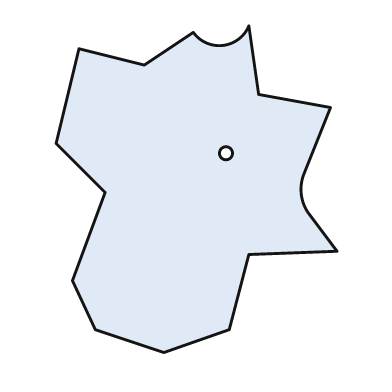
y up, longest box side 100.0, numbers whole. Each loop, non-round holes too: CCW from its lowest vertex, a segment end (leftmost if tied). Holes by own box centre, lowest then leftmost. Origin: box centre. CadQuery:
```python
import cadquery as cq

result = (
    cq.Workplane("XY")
    .moveTo(-10.0, -50.0)
    .lineTo(10.0, -43.0)
    .lineTo(16.0, -20.0)
    .lineTo(43.0, -19.0)
    .lineTo(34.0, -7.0)
    .threePointArc((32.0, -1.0), (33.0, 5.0))
    .lineTo(41.0, 25.0)
    .lineTo(19.0, 29.0)
    .lineTo(16.0, 50.0)
    .threePointArc((8.0, 44.0), (-1.0, 48.0))
    .lineTo(-16.0, 38.0)
    .lineTo(-36.0, 43.0)
    .lineTo(-43.0, 14.0)
    .lineTo(-28.0, -1.0)
    .lineTo(-38.0, -28.0)
    .lineTo(-31.0, -43.0)
    .close()
    .moveTo(9.0, 11.0)
    .circle(2.0)
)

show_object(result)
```